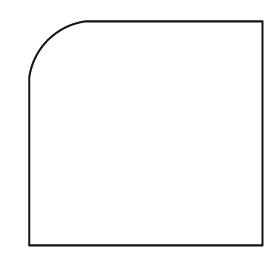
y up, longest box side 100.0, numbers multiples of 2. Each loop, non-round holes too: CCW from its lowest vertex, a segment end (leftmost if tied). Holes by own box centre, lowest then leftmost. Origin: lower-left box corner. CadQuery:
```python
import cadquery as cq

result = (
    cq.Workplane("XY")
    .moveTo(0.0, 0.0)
    .lineTo(100.0, 0.0)
    .lineTo(100.0, 96.0)
    .lineTo(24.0, 96.0)
    .threePointArc((8.0, 88.0), (0.0, 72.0))
    .close()
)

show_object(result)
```